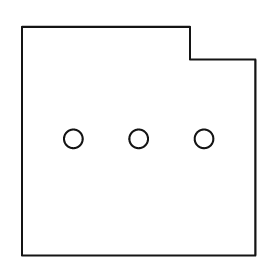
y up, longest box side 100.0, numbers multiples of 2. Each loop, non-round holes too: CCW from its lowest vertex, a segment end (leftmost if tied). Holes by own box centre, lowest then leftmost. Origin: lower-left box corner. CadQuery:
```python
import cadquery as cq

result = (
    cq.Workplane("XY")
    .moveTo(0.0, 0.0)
    .lineTo(100.0, 0.0)
    .lineTo(100.0, 84.0)
    .lineTo(72.0, 84.0)
    .lineTo(72.0, 98.0)
    .lineTo(0.0, 98.0)
    .close()
    .moveTo(22.0, 50.0)
    .circle(4.0)
    .moveTo(50.0, 50.0)
    .circle(4.0)
    .moveTo(78.0, 50.0)
    .circle(4.0)
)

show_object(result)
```